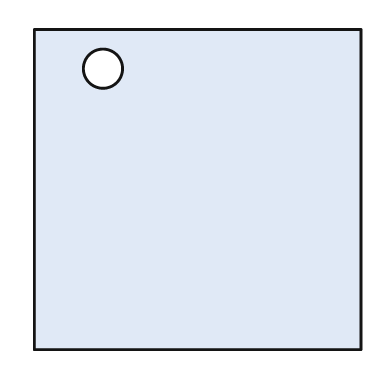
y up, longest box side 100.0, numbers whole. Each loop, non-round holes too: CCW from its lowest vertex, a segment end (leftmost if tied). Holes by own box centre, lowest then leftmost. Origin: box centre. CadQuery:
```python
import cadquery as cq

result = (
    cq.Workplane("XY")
    .moveTo(-50.0, -49.0)
    .lineTo(50.0, -49.0)
    .lineTo(50.0, 49.0)
    .lineTo(-50.0, 49.0)
    .close()
    .moveTo(-29.0, 37.0)
    .circle(6.0)
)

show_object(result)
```